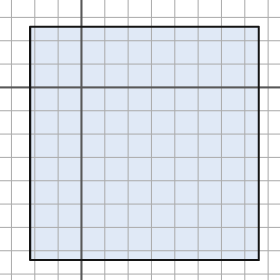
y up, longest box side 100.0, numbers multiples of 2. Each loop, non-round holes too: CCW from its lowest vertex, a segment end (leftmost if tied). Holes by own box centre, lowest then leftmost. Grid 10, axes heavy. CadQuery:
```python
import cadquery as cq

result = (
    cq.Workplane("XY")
    .moveTo(-22.0, -74.0)
    .lineTo(76.0, -74.0)
    .lineTo(76.0, 26.0)
    .lineTo(-22.0, 26.0)
    .close()
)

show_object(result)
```